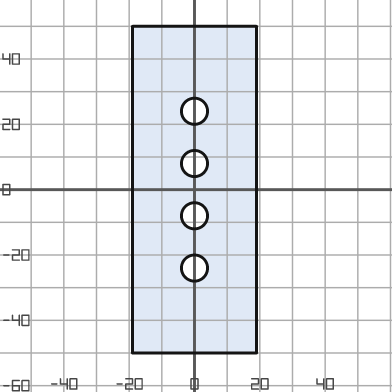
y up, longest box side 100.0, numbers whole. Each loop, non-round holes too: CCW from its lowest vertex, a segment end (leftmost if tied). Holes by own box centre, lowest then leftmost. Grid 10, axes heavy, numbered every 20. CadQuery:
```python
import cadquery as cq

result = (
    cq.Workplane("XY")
    .moveTo(-19.0, -50.0)
    .lineTo(19.0, -50.0)
    .lineTo(19.0, 50.0)
    .lineTo(-19.0, 50.0)
    .close()
    .moveTo(0.0, -24.0)
    .circle(4.0)
    .moveTo(0.0, -8.0)
    .circle(4.0)
    .moveTo(0.0, 8.0)
    .circle(4.0)
    .moveTo(0.0, 24.0)
    .circle(4.0)
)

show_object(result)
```